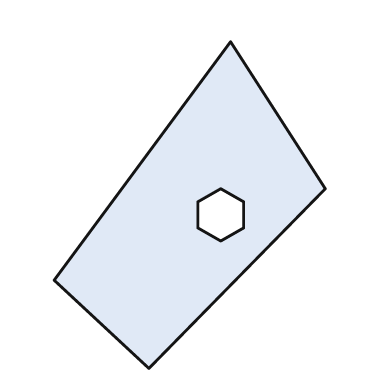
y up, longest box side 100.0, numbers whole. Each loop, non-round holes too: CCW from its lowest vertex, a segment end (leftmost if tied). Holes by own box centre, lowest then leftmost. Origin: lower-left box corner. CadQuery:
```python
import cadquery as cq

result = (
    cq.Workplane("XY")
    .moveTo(29.0, 0.0)
    .lineTo(83.0, 55.0)
    .lineTo(54.0, 100.0)
    .lineTo(0.0, 27.0)
    .close()
    .moveTo(51.0, 39.0)
    .lineTo(58.0, 43.0)
    .lineTo(58.0, 51.0)
    .lineTo(51.0, 55.0)
    .lineTo(44.0, 51.0)
    .lineTo(44.0, 43.0)
    .close()
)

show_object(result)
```